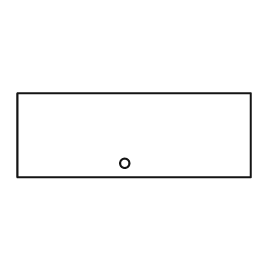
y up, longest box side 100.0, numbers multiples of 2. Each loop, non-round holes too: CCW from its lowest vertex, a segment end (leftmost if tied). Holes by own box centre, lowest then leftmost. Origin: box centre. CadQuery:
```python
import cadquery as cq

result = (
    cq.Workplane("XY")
    .moveTo(-50.0, -18.0)
    .lineTo(50.0, -18.0)
    .lineTo(50.0, 18.0)
    .lineTo(-50.0, 18.0)
    .close()
    .moveTo(-4.0, -12.0)
    .circle(2.0)
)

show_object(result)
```